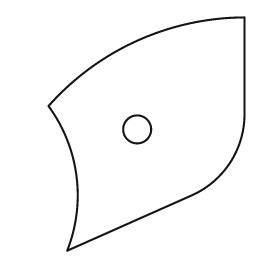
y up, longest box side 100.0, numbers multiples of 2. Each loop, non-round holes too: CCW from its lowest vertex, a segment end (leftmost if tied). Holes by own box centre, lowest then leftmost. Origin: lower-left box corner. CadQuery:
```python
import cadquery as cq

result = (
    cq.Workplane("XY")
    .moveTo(8.0, 0.0)
    .lineTo(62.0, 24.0)
    .threePointArc((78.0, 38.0), (84.0, 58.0))
    .lineTo(84.0, 100.0)
    .threePointArc((38.0, 90.0), (0.0, 62.0))
    .threePointArc((12.0, 32.0), (8.0, 0.0))
    .close()
    .moveTo(38.0, 52.0)
    .circle(6.0)
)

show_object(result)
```